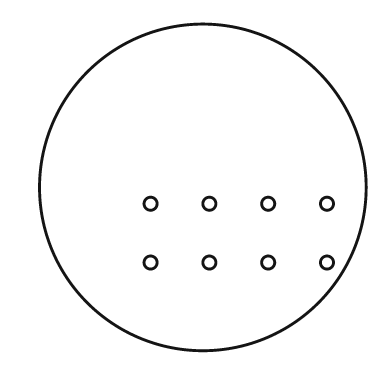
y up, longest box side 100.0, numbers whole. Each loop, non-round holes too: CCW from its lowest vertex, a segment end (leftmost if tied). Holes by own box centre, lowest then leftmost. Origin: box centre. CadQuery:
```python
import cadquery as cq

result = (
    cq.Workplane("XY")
    .moveTo(0.0, 0.0)
    .circle(50.0)
    .moveTo(-16.0, -23.0)
    .circle(2.0)
    .moveTo(2.0, -23.0)
    .circle(2.0)
    .moveTo(20.0, -23.0)
    .circle(2.0)
    .moveTo(38.0, -23.0)
    .circle(2.0)
    .moveTo(-16.0, -5.0)
    .circle(2.0)
    .moveTo(2.0, -5.0)
    .circle(2.0)
    .moveTo(20.0, -5.0)
    .circle(2.0)
    .moveTo(38.0, -5.0)
    .circle(2.0)
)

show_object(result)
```